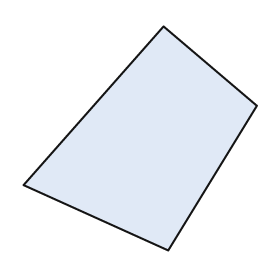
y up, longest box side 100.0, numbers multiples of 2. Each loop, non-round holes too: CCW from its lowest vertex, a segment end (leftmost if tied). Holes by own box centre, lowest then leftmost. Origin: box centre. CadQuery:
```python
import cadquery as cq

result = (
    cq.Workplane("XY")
    .moveTo(12.0, -48.0)
    .lineTo(50.0, 14.0)
    .lineTo(10.0, 48.0)
    .lineTo(-50.0, -20.0)
    .close()
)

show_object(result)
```